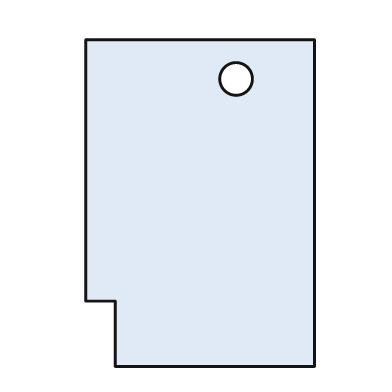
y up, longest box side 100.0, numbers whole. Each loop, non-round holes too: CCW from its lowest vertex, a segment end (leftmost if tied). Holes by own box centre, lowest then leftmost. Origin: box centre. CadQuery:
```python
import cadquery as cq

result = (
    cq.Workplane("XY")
    .moveTo(-26.0, -50.0)
    .lineTo(35.0, -50.0)
    .lineTo(35.0, 50.0)
    .lineTo(-35.0, 50.0)
    .lineTo(-35.0, -30.0)
    .lineTo(-26.0, -30.0)
    .close()
    .moveTo(11.0, 38.0)
    .circle(5.0)
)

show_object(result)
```